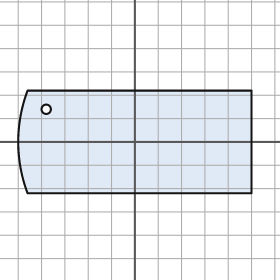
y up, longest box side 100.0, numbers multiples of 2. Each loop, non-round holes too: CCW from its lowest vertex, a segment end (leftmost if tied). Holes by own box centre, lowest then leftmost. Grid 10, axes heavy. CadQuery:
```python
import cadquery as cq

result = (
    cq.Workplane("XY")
    .moveTo(-46.0, -22.0)
    .lineTo(50.0, -22.0)
    .lineTo(50.0, 22.0)
    .lineTo(-46.0, 22.0)
    .threePointArc((-50.0, 0.0), (-46.0, -22.0))
    .close()
    .moveTo(-38.0, 14.0)
    .circle(2.0)
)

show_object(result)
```